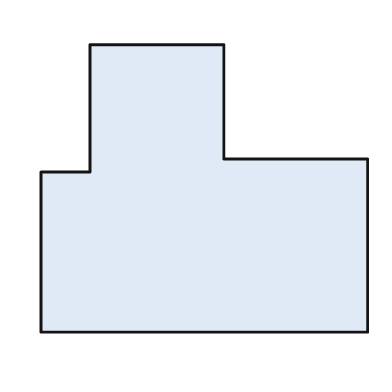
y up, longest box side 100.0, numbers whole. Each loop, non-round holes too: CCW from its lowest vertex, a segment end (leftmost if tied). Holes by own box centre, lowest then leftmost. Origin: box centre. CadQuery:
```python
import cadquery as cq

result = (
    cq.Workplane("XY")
    .moveTo(-50.0, -44.0)
    .lineTo(50.0, -44.0)
    .lineTo(50.0, 9.0)
    .lineTo(6.0, 9.0)
    .lineTo(6.0, 44.0)
    .lineTo(-35.0, 44.0)
    .lineTo(-35.0, 5.0)
    .lineTo(-50.0, 5.0)
    .close()
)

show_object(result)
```